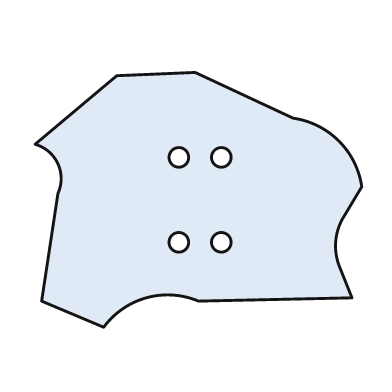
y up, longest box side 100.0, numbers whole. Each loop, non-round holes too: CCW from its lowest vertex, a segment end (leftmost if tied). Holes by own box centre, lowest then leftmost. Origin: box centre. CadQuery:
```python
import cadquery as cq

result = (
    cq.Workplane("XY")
    .moveTo(-29.0, -39.0)
    .threePointArc((-16.0, -30.0), (0.0, -31.0))
    .lineTo(47.0, -30.0)
    .lineTo(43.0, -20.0)
    .threePointArc((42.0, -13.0), (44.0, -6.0))
    .lineTo(50.0, 4.0)
    .threePointArc((43.0, 18.0), (29.0, 25.0))
    .lineTo(-1.0, 39.0)
    .lineTo(-25.0, 38.0)
    .lineTo(-50.0, 17.0)
    .threePointArc((-43.0, 11.0), (-43.0, 2.0))
    .lineTo(-48.0, -31.0)
    .close()
    .moveTo(-6.0, -13.0)
    .circle(3.0)
    .moveTo(7.0, -13.0)
    .circle(3.0)
    .moveTo(-6.0, 13.0)
    .circle(3.0)
    .moveTo(7.0, 13.0)
    .circle(3.0)
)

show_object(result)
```